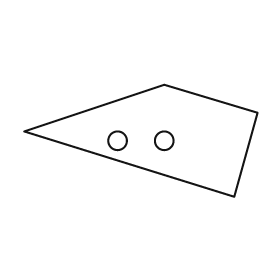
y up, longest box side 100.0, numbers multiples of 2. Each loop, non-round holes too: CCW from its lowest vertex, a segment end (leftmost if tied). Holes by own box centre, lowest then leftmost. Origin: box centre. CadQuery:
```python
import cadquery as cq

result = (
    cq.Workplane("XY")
    .moveTo(40.0, -24.0)
    .lineTo(50.0, 12.0)
    .lineTo(10.0, 24.0)
    .lineTo(-50.0, 4.0)
    .close()
    .moveTo(-10.0, 0.0)
    .circle(4.0)
    .moveTo(10.0, 0.0)
    .circle(4.0)
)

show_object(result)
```